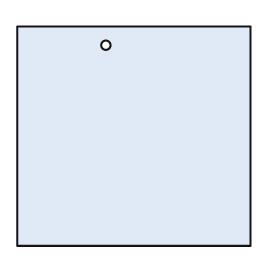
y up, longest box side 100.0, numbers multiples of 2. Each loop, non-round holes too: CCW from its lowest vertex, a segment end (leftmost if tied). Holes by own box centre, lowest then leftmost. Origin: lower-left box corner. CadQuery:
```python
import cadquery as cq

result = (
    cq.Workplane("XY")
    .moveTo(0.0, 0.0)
    .lineTo(100.0, 0.0)
    .lineTo(100.0, 94.0)
    .lineTo(0.0, 94.0)
    .close()
    .moveTo(38.0, 86.0)
    .circle(2.0)
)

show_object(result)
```